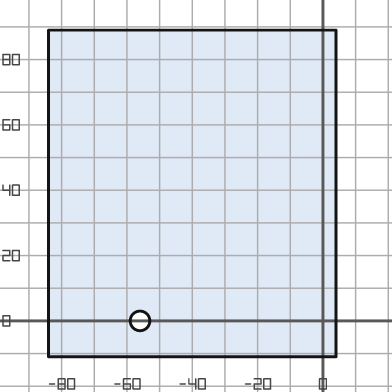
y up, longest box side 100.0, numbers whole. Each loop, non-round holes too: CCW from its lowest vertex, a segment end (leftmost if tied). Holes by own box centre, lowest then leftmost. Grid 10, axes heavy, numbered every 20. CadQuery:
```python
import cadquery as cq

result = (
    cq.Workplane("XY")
    .moveTo(-84.0, -11.0)
    .lineTo(4.0, -11.0)
    .lineTo(4.0, 89.0)
    .lineTo(-84.0, 89.0)
    .close()
    .moveTo(-56.0, 0.0)
    .circle(3.0)
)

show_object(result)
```